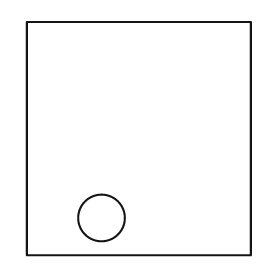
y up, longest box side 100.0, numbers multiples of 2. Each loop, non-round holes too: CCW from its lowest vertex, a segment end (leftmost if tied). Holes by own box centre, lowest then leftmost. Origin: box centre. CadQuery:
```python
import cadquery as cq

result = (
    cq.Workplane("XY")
    .moveTo(-48.0, -50.0)
    .lineTo(48.0, -50.0)
    .lineTo(48.0, 50.0)
    .lineTo(-48.0, 50.0)
    .close()
    .moveTo(-16.0, -34.0)
    .circle(10.0)
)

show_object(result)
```